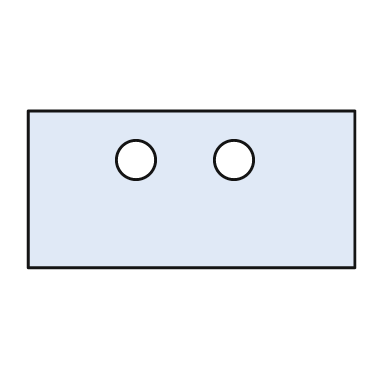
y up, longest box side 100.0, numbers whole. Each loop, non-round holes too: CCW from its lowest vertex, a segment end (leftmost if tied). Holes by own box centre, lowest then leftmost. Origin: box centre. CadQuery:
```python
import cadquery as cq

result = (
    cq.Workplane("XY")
    .moveTo(-50.0, -24.0)
    .lineTo(50.0, -24.0)
    .lineTo(50.0, 24.0)
    .lineTo(-50.0, 24.0)
    .close()
    .moveTo(-17.0, 9.0)
    .circle(6.0)
    .moveTo(13.0, 9.0)
    .circle(6.0)
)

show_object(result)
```